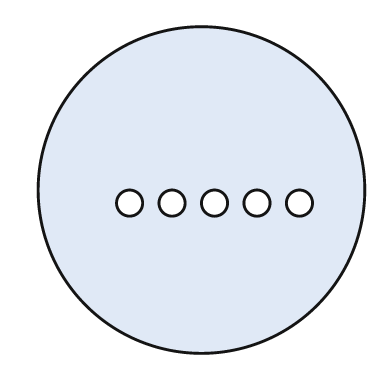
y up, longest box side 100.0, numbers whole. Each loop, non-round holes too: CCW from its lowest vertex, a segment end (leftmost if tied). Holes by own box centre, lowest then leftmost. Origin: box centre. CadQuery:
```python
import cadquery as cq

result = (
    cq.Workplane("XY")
    .moveTo(0.0, 0.0)
    .circle(50.0)
    .moveTo(-22.0, -4.0)
    .circle(4.0)
    .moveTo(-9.0, -4.0)
    .circle(4.0)
    .moveTo(4.0, -4.0)
    .circle(4.0)
    .moveTo(17.0, -4.0)
    .circle(4.0)
    .moveTo(30.0, -4.0)
    .circle(4.0)
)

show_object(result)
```